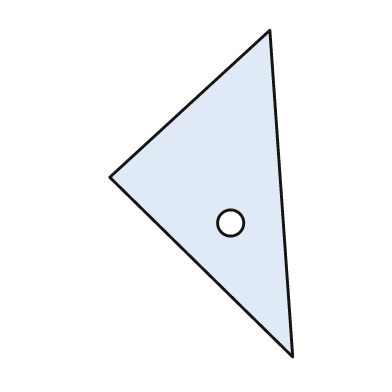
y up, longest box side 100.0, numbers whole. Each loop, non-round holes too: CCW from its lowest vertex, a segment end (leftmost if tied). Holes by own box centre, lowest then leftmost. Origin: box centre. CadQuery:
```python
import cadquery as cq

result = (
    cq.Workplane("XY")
    .moveTo(28.0, -50.0)
    .lineTo(21.0, 50.0)
    .lineTo(-28.0, 5.0)
    .close()
    .moveTo(9.0, -9.0)
    .circle(4.0)
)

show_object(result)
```